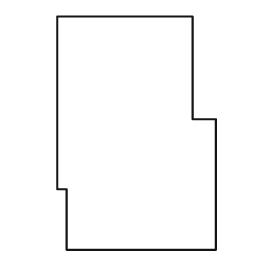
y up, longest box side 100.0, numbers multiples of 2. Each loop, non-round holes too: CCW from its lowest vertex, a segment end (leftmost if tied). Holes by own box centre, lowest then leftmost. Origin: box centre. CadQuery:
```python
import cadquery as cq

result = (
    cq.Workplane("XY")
    .moveTo(-30.0, -50.0)
    .lineTo(34.0, -50.0)
    .lineTo(34.0, 6.0)
    .lineTo(24.0, 6.0)
    .lineTo(24.0, 50.0)
    .lineTo(-34.0, 50.0)
    .lineTo(-34.0, -24.0)
    .lineTo(-30.0, -24.0)
    .close()
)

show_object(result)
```